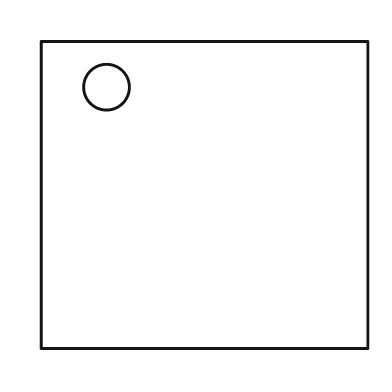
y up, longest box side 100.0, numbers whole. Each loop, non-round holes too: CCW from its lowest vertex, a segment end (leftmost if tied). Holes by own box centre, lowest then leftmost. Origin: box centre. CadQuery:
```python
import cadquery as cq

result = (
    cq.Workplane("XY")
    .moveTo(-50.0, -47.0)
    .lineTo(50.0, -47.0)
    .lineTo(50.0, 47.0)
    .lineTo(-50.0, 47.0)
    .close()
    .moveTo(-30.0, 33.0)
    .circle(7.0)
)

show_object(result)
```